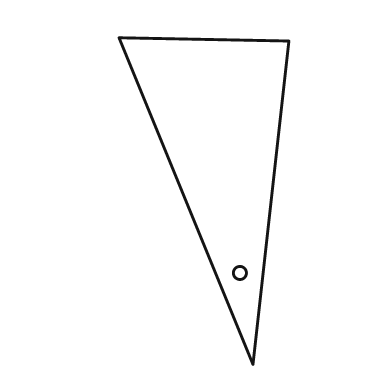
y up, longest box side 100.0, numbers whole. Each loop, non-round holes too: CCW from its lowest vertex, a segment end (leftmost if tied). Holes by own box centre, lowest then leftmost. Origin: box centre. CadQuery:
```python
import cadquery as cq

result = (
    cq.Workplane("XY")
    .moveTo(15.0, -50.0)
    .lineTo(26.0, 49.0)
    .lineTo(-26.0, 50.0)
    .close()
    .moveTo(11.0, -22.0)
    .circle(2.0)
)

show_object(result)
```